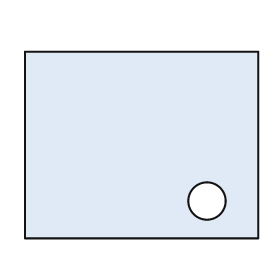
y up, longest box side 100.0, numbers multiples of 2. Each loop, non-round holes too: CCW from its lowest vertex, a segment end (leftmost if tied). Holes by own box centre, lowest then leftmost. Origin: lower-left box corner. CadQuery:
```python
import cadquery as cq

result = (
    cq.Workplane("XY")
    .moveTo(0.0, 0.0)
    .lineTo(100.0, 0.0)
    .lineTo(100.0, 80.0)
    .lineTo(0.0, 80.0)
    .close()
    .moveTo(78.0, 16.0)
    .circle(8.0)
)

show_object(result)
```